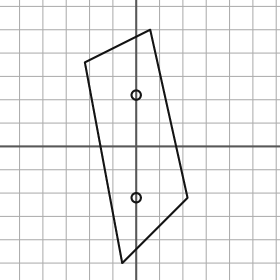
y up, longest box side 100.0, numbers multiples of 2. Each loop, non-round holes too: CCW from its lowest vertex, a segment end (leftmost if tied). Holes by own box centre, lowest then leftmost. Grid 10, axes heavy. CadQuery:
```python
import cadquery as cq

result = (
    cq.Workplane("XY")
    .moveTo(-6.0, -50.0)
    .lineTo(22.0, -22.0)
    .lineTo(6.0, 50.0)
    .lineTo(-22.0, 36.0)
    .close()
    .moveTo(0.0, -22.0)
    .circle(2.0)
    .moveTo(0.0, 22.0)
    .circle(2.0)
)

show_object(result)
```